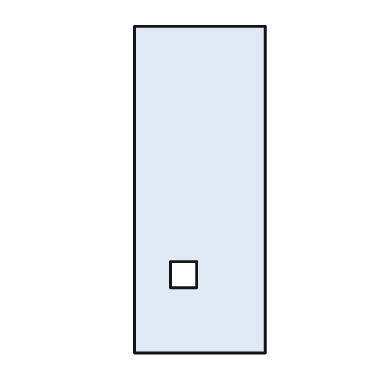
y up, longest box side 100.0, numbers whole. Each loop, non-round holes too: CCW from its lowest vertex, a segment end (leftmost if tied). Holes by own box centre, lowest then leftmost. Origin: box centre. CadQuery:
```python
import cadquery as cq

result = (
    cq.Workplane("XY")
    .moveTo(-20.0, -50.0)
    .lineTo(20.0, -50.0)
    .lineTo(20.0, 50.0)
    .lineTo(-20.0, 50.0)
    .close()
    .moveTo(-9.0, -30.0)
    .lineTo(-1.0, -30.0)
    .lineTo(-1.0, -22.0)
    .lineTo(-9.0, -22.0)
    .close()
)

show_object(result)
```